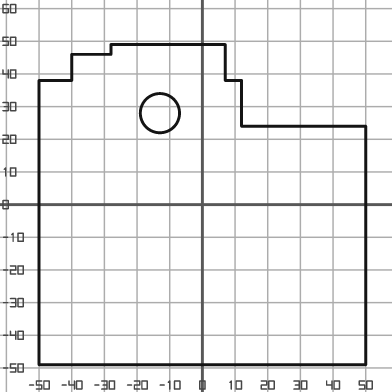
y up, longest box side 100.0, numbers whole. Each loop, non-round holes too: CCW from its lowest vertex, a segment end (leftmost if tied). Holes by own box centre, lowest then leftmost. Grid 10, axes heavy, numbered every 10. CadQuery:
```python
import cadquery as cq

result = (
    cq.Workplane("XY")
    .moveTo(-50.0, -49.0)
    .lineTo(50.0, -49.0)
    .lineTo(50.0, 24.0)
    .lineTo(12.0, 24.0)
    .lineTo(12.0, 38.0)
    .lineTo(7.0, 38.0)
    .lineTo(7.0, 49.0)
    .lineTo(-28.0, 49.0)
    .lineTo(-28.0, 46.0)
    .lineTo(-40.0, 46.0)
    .lineTo(-40.0, 38.0)
    .lineTo(-50.0, 38.0)
    .close()
    .moveTo(-13.0, 28.0)
    .circle(6.0)
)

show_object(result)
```